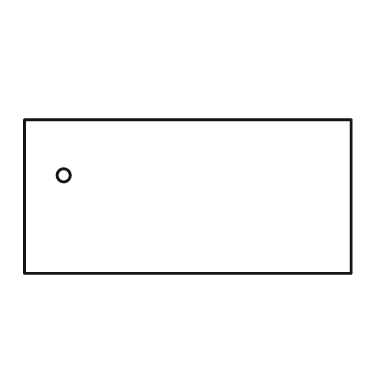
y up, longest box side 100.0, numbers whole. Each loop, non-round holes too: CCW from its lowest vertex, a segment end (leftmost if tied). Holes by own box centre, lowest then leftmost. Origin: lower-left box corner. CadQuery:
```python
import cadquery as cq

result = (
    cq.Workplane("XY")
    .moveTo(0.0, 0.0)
    .lineTo(100.0, 0.0)
    .lineTo(100.0, 47.0)
    .lineTo(0.0, 47.0)
    .close()
    .moveTo(12.0, 30.0)
    .circle(2.0)
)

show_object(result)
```